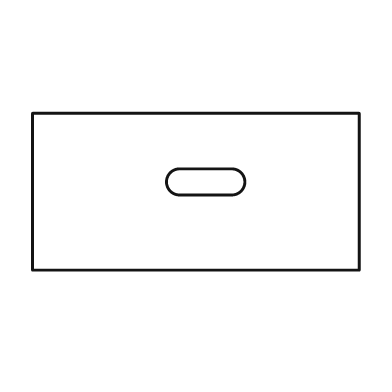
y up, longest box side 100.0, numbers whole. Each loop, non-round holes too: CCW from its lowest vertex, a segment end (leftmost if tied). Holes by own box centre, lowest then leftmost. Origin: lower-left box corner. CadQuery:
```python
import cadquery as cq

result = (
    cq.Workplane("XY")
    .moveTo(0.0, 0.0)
    .lineTo(100.0, 0.0)
    .lineTo(100.0, 48.0)
    .lineTo(0.0, 48.0)
    .close()
    .moveTo(45.0, 23.0)
    .lineTo(61.0, 23.0)
    .threePointArc((65.0, 27.0), (61.0, 31.0))
    .lineTo(45.0, 31.0)
    .threePointArc((41.0, 27.0), (45.0, 23.0))
    .close()
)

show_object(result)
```